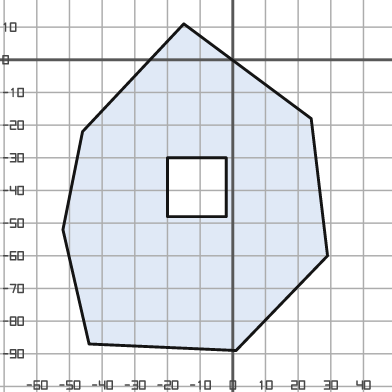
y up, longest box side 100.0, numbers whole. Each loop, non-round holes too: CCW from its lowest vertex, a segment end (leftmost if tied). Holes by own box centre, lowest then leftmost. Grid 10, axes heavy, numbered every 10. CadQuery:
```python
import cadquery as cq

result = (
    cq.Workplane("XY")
    .moveTo(1.0, -89.0)
    .lineTo(29.0, -60.0)
    .lineTo(24.0, -18.0)
    .lineTo(-15.0, 11.0)
    .lineTo(-46.0, -22.0)
    .lineTo(-52.0, -52.0)
    .lineTo(-44.0, -87.0)
    .close()
    .moveTo(-20.0, -48.0)
    .lineTo(-2.0, -48.0)
    .lineTo(-2.0, -30.0)
    .lineTo(-20.0, -30.0)
    .close()
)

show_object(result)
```